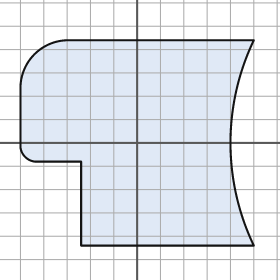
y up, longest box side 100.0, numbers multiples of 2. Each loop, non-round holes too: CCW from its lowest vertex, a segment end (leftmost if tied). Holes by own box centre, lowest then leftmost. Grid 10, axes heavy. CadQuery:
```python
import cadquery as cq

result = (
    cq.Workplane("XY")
    .moveTo(-24.0, -44.0)
    .lineTo(50.0, -44.0)
    .threePointArc((40.0, 0.0), (50.0, 44.0))
    .lineTo(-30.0, 44.0)
    .threePointArc((-44.0, 38.0), (-50.0, 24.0))
    .lineTo(-50.0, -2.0)
    .threePointArc((-48.0, -6.0), (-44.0, -8.0))
    .lineTo(-24.0, -8.0)
    .close()
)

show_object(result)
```